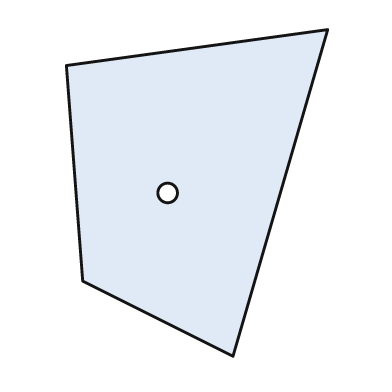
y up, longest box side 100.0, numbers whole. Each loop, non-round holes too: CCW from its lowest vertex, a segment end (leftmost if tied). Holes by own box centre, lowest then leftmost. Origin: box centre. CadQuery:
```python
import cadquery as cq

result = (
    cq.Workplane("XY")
    .moveTo(11.0, -50.0)
    .lineTo(40.0, 50.0)
    .lineTo(-40.0, 39.0)
    .lineTo(-35.0, -27.0)
    .close()
    .moveTo(-9.0, 0.0)
    .circle(3.0)
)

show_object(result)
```